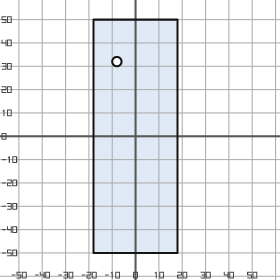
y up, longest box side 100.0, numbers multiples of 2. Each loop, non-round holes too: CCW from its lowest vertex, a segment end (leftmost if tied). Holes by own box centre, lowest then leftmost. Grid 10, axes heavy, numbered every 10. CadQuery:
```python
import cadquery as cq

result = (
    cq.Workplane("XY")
    .moveTo(-18.0, -50.0)
    .lineTo(18.0, -50.0)
    .lineTo(18.0, 50.0)
    .lineTo(-18.0, 50.0)
    .close()
    .moveTo(-8.0, 32.0)
    .circle(2.0)
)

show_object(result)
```